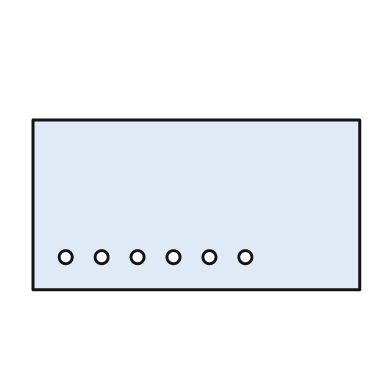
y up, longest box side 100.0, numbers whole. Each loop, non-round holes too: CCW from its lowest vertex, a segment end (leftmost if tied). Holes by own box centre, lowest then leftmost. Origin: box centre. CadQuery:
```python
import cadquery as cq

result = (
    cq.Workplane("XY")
    .moveTo(-50.0, -26.0)
    .lineTo(50.0, -26.0)
    .lineTo(50.0, 26.0)
    .lineTo(-50.0, 26.0)
    .close()
    .moveTo(-40.0, -16.0)
    .circle(2.0)
    .moveTo(-29.0, -16.0)
    .circle(2.0)
    .moveTo(-18.0, -16.0)
    .circle(2.0)
    .moveTo(-7.0, -16.0)
    .circle(2.0)
    .moveTo(4.0, -16.0)
    .circle(2.0)
    .moveTo(15.0, -16.0)
    .circle(2.0)
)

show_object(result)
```